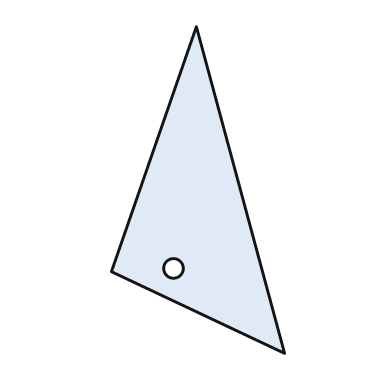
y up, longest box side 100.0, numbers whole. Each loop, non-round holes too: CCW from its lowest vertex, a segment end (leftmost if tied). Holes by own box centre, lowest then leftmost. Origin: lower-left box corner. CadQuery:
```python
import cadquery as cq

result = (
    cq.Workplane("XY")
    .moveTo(53.0, 0.0)
    .lineTo(26.0, 100.0)
    .lineTo(0.0, 25.0)
    .close()
    .moveTo(19.0, 26.0)
    .circle(3.0)
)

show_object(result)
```